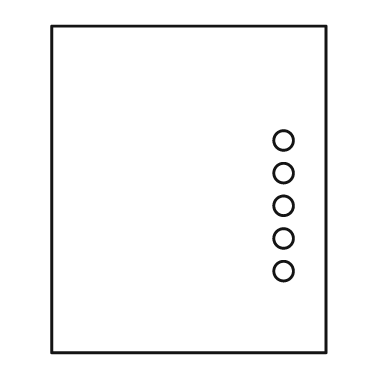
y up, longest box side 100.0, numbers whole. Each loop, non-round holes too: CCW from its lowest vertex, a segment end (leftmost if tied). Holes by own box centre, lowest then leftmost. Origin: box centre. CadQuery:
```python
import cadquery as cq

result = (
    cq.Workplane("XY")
    .moveTo(-42.0, -50.0)
    .lineTo(42.0, -50.0)
    .lineTo(42.0, 50.0)
    .lineTo(-42.0, 50.0)
    .close()
    .moveTo(29.0, -25.0)
    .circle(3.0)
    .moveTo(29.0, -15.0)
    .circle(3.0)
    .moveTo(29.0, -5.0)
    .circle(3.0)
    .moveTo(29.0, 5.0)
    .circle(3.0)
    .moveTo(29.0, 15.0)
    .circle(3.0)
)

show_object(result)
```